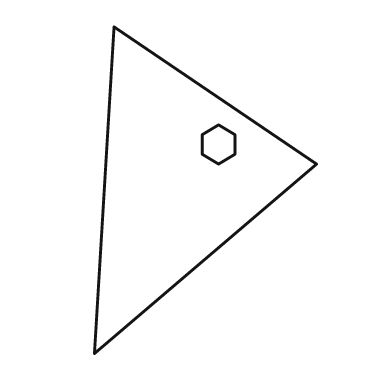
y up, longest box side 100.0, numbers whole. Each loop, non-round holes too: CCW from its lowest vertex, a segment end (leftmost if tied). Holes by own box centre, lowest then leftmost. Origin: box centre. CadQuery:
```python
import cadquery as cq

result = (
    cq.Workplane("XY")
    .moveTo(-34.0, -50.0)
    .lineTo(34.0, 8.0)
    .lineTo(-28.0, 50.0)
    .close()
    .moveTo(4.0, 8.0)
    .lineTo(9.0, 11.0)
    .lineTo(9.0, 17.0)
    .lineTo(4.0, 20.0)
    .lineTo(-1.0, 17.0)
    .lineTo(-1.0, 11.0)
    .close()
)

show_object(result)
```